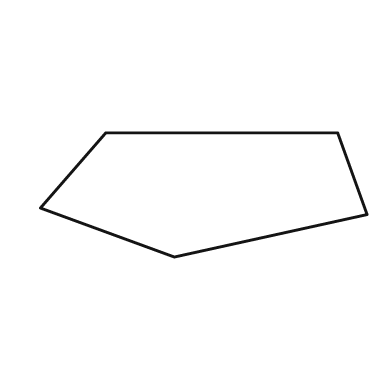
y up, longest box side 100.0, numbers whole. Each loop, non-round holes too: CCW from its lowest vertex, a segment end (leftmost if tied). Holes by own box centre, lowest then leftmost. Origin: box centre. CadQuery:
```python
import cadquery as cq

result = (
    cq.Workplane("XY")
    .moveTo(-9.0, -19.0)
    .lineTo(50.0, -6.0)
    .lineTo(41.0, 19.0)
    .lineTo(-30.0, 19.0)
    .lineTo(-50.0, -4.0)
    .close()
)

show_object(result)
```